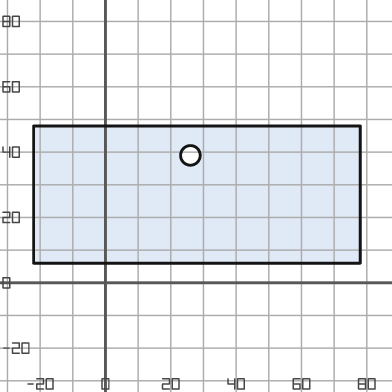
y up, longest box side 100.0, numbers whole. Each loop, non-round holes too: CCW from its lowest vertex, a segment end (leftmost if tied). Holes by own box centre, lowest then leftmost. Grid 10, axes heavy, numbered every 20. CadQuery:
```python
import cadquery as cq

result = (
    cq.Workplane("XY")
    .moveTo(-22.0, 6.0)
    .lineTo(78.0, 6.0)
    .lineTo(78.0, 48.0)
    .lineTo(-22.0, 48.0)
    .close()
    .moveTo(26.0, 39.0)
    .circle(3.0)
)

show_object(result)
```